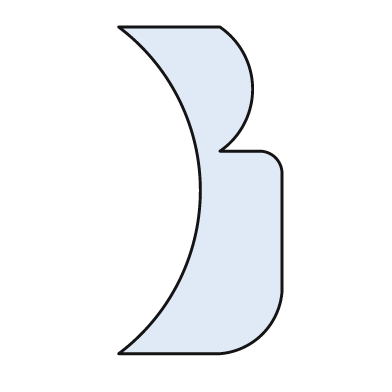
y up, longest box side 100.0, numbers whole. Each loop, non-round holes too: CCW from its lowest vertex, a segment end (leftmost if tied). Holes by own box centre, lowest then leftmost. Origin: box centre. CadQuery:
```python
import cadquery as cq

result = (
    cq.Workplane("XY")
    .moveTo(-25.0, -50.0)
    .lineTo(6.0, -50.0)
    .threePointArc((19.0, -44.0), (25.0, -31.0))
    .lineTo(25.0, 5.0)
    .threePointArc((23.0, 10.0), (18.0, 12.0))
    .lineTo(6.0, 12.0)
    .threePointArc((16.0, 31.0), (6.0, 50.0))
    .lineTo(-25.0, 50.0)
    .threePointArc((0.0, 0.0), (-25.0, -50.0))
    .close()
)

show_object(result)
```